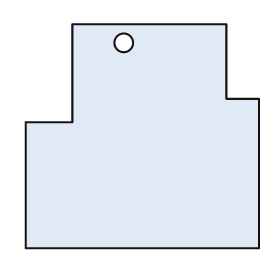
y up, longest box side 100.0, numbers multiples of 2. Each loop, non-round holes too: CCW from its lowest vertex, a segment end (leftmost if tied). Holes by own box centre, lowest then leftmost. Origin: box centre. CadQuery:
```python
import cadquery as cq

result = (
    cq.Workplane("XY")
    .moveTo(-50.0, -48.0)
    .lineTo(50.0, -48.0)
    .lineTo(50.0, 16.0)
    .lineTo(36.0, 16.0)
    .lineTo(36.0, 48.0)
    .lineTo(-30.0, 48.0)
    .lineTo(-30.0, 6.0)
    .lineTo(-50.0, 6.0)
    .close()
    .moveTo(-8.0, 40.0)
    .circle(4.0)
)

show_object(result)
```